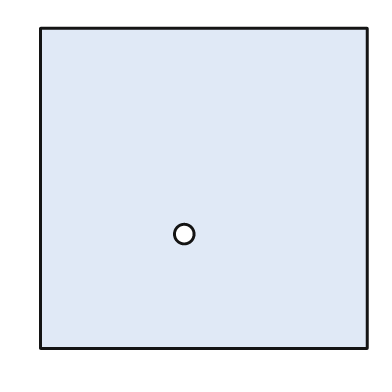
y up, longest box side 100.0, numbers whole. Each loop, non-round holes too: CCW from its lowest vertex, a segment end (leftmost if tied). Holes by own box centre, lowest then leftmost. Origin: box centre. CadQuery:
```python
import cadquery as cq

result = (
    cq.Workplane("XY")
    .moveTo(-50.0, -49.0)
    .lineTo(50.0, -49.0)
    .lineTo(50.0, 49.0)
    .lineTo(-50.0, 49.0)
    .close()
    .moveTo(-6.0, -14.0)
    .circle(3.0)
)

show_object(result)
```